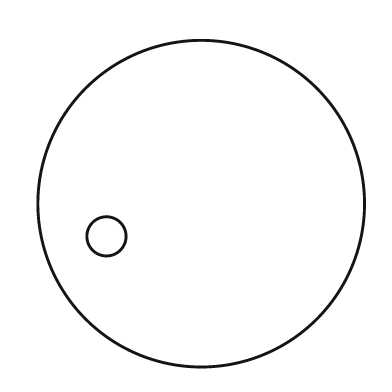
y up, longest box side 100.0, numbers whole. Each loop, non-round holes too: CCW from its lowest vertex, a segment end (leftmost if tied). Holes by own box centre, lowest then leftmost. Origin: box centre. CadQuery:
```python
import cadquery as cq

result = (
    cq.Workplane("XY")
    .moveTo(0.0, 0.0)
    .circle(50.0)
    .moveTo(-29.0, -10.0)
    .circle(6.0)
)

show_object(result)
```